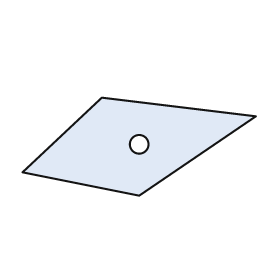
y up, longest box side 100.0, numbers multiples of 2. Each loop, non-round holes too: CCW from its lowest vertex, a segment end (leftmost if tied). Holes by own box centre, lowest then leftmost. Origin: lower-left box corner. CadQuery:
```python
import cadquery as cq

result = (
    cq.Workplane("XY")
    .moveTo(50.0, 0.0)
    .lineTo(100.0, 34.0)
    .lineTo(34.0, 42.0)
    .lineTo(0.0, 10.0)
    .close()
    .moveTo(50.0, 22.0)
    .circle(4.0)
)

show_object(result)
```